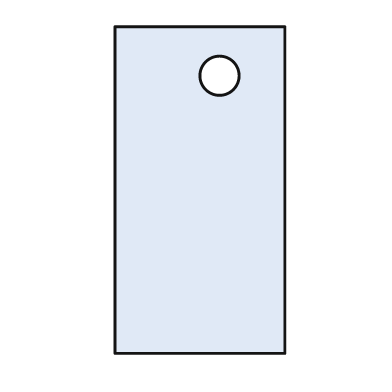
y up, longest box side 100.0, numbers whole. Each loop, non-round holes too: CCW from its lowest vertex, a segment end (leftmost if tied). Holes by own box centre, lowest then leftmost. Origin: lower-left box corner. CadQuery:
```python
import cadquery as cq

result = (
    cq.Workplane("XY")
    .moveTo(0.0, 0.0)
    .lineTo(52.0, 0.0)
    .lineTo(52.0, 100.0)
    .lineTo(0.0, 100.0)
    .close()
    .moveTo(32.0, 85.0)
    .circle(6.0)
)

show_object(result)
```